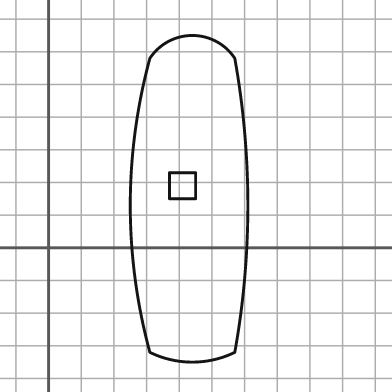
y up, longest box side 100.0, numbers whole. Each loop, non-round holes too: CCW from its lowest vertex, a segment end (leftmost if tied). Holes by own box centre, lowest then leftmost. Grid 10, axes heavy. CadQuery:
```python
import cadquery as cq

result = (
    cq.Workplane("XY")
    .moveTo(31.0, -32.0)
    .threePointArc((44.0, -35.0), (57.0, -32.0))
    .threePointArc((61.0, 13.0), (57.0, 58.0))
    .threePointArc((44.0, 65.0), (31.0, 58.0))
    .threePointArc((25.0, 13.0), (31.0, -32.0))
    .close()
    .moveTo(37.0, 15.0)
    .lineTo(45.0, 15.0)
    .lineTo(45.0, 23.0)
    .lineTo(37.0, 23.0)
    .close()
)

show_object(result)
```